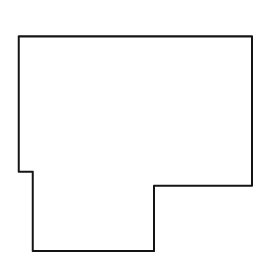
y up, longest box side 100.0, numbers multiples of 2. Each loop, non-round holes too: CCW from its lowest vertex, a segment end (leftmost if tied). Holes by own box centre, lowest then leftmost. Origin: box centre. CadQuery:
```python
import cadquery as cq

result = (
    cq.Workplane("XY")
    .moveTo(-44.0, -46.0)
    .lineTo(8.0, -46.0)
    .lineTo(8.0, -18.0)
    .lineTo(50.0, -18.0)
    .lineTo(50.0, 46.0)
    .lineTo(-50.0, 46.0)
    .lineTo(-50.0, -12.0)
    .lineTo(-44.0, -12.0)
    .close()
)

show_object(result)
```